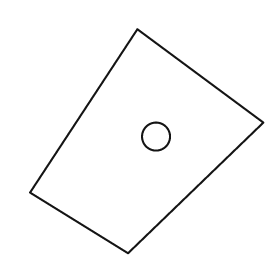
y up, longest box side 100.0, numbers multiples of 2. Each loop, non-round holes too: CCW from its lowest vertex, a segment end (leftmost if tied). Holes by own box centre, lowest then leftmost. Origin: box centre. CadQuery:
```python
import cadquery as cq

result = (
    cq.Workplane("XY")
    .moveTo(-8.0, -48.0)
    .lineTo(50.0, 8.0)
    .lineTo(-4.0, 48.0)
    .lineTo(-50.0, -22.0)
    .close()
    .moveTo(4.0, 2.0)
    .circle(6.0)
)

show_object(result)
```